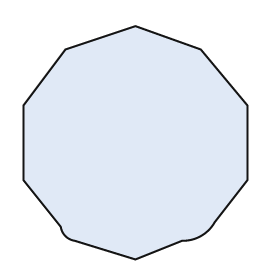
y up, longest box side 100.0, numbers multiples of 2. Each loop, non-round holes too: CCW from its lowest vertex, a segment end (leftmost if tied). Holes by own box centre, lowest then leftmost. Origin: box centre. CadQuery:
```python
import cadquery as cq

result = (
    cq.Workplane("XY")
    .moveTo(0.0, -50.0)
    .lineTo(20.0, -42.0)
    .threePointArc((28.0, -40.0), (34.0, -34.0))
    .lineTo(48.0, -16.0)
    .lineTo(48.0, 16.0)
    .lineTo(28.0, 40.0)
    .lineTo(0.0, 50.0)
    .lineTo(-30.0, 40.0)
    .lineTo(-48.0, 16.0)
    .lineTo(-48.0, -16.0)
    .lineTo(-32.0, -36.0)
    .threePointArc((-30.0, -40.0), (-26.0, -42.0))
    .close()
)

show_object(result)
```